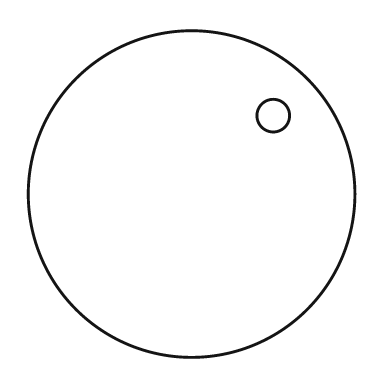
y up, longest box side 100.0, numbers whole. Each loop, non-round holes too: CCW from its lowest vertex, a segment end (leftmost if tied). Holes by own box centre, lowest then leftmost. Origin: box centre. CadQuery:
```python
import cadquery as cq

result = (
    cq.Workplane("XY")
    .moveTo(0.0, 0.0)
    .circle(50.0)
    .moveTo(25.0, 24.0)
    .circle(5.0)
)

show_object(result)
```